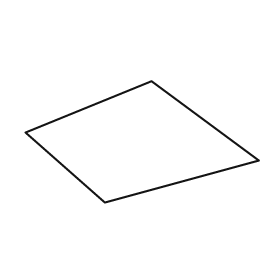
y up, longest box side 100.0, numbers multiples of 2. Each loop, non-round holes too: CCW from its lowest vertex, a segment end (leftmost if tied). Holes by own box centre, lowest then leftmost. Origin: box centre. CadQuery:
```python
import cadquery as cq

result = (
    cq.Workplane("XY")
    .moveTo(-16.0, -26.0)
    .lineTo(50.0, -8.0)
    .lineTo(4.0, 26.0)
    .lineTo(-50.0, 4.0)
    .close()
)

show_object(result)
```